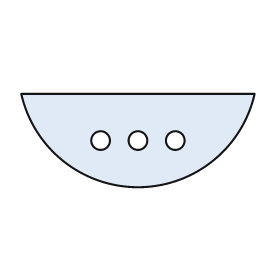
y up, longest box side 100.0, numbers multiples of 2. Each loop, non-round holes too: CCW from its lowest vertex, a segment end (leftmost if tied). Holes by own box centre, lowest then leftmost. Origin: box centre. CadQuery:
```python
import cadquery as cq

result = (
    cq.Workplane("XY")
    .moveTo(-50.0, 20.0)
    .threePointArc((0.0, -20.0), (50.0, 20.0))
    .close()
    .moveTo(-16.0, 0.0)
    .circle(4.0)
    .moveTo(0.0, 0.0)
    .circle(4.0)
    .moveTo(16.0, 0.0)
    .circle(4.0)
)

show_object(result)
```